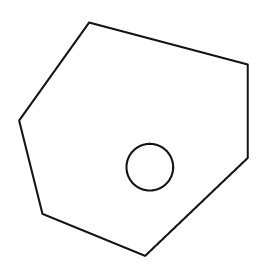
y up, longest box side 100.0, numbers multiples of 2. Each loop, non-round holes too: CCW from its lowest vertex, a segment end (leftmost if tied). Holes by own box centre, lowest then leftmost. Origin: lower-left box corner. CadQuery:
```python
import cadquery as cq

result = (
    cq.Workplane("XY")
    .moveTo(54.0, 0.0)
    .lineTo(98.0, 42.0)
    .lineTo(98.0, 82.0)
    .lineTo(30.0, 100.0)
    .lineTo(0.0, 58.0)
    .lineTo(10.0, 18.0)
    .close()
    .moveTo(56.0, 38.0)
    .circle(10.0)
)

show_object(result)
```